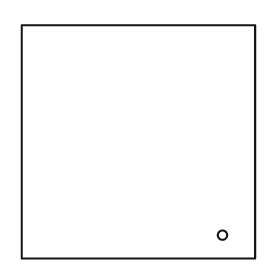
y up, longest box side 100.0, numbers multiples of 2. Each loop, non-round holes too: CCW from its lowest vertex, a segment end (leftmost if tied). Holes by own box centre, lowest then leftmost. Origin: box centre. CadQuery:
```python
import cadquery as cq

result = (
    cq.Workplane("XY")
    .moveTo(-50.0, -50.0)
    .lineTo(50.0, -50.0)
    .lineTo(50.0, 50.0)
    .lineTo(-50.0, 50.0)
    .close()
    .moveTo(36.0, -40.0)
    .circle(2.0)
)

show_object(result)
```